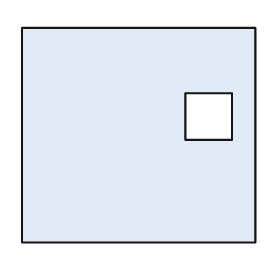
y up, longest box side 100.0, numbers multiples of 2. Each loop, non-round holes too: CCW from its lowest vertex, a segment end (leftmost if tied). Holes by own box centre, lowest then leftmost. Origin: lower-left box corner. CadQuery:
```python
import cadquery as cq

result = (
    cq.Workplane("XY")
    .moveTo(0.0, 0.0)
    .lineTo(100.0, 0.0)
    .lineTo(100.0, 92.0)
    .lineTo(0.0, 92.0)
    .close()
    .moveTo(70.0, 44.0)
    .lineTo(90.0, 44.0)
    .lineTo(90.0, 64.0)
    .lineTo(70.0, 64.0)
    .close()
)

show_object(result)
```